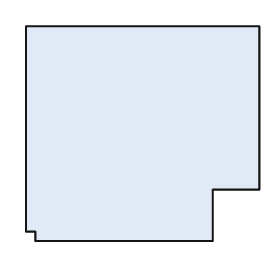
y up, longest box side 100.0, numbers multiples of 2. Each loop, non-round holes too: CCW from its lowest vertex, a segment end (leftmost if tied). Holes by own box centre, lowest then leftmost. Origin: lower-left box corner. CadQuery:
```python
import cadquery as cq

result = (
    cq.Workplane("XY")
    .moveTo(4.0, 0.0)
    .lineTo(80.0, 0.0)
    .lineTo(80.0, 22.0)
    .lineTo(100.0, 22.0)
    .lineTo(100.0, 92.0)
    .lineTo(0.0, 92.0)
    .lineTo(0.0, 4.0)
    .lineTo(4.0, 4.0)
    .close()
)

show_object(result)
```